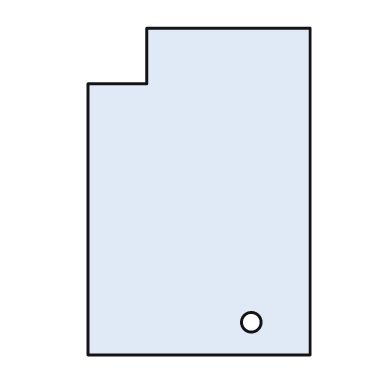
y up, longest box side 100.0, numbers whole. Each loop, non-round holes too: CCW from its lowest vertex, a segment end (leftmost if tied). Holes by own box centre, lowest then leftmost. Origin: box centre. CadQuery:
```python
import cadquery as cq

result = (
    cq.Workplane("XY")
    .moveTo(-34.0, -50.0)
    .lineTo(34.0, -50.0)
    .lineTo(34.0, 50.0)
    .lineTo(-16.0, 50.0)
    .lineTo(-16.0, 33.0)
    .lineTo(-34.0, 33.0)
    .close()
    .moveTo(16.0, -40.0)
    .circle(3.0)
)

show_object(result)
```